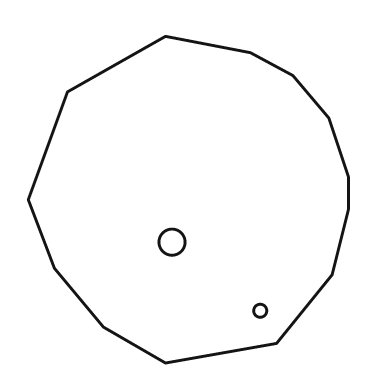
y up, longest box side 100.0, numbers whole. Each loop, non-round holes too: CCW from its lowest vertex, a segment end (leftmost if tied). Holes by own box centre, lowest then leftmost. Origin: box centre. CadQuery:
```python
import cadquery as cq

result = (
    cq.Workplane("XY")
    .moveTo(-7.0, -50.0)
    .lineTo(27.0, -44.0)
    .lineTo(44.0, -23.0)
    .lineTo(49.0, -3.0)
    .lineTo(49.0, 7.0)
    .lineTo(43.0, 25.0)
    .lineTo(32.0, 38.0)
    .lineTo(19.0, 45.0)
    .lineTo(-7.0, 50.0)
    .lineTo(-37.0, 33.0)
    .lineTo(-49.0, 0.0)
    .lineTo(-41.0, -21.0)
    .lineTo(-26.0, -39.0)
    .close()
    .moveTo(22.0, -34.0)
    .circle(2.0)
    .moveTo(-5.0, -13.0)
    .circle(4.0)
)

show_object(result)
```